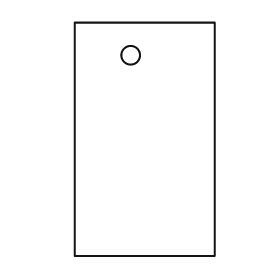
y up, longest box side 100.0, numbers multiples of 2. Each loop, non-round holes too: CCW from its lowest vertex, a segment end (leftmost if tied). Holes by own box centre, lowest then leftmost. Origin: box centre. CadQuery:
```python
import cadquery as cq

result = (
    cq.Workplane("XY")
    .moveTo(-30.0, -50.0)
    .lineTo(30.0, -50.0)
    .lineTo(30.0, 50.0)
    .lineTo(-30.0, 50.0)
    .close()
    .moveTo(-6.0, 36.0)
    .circle(4.0)
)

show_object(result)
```